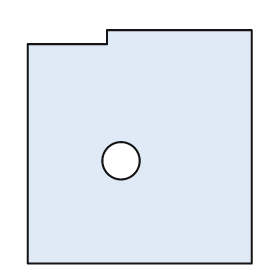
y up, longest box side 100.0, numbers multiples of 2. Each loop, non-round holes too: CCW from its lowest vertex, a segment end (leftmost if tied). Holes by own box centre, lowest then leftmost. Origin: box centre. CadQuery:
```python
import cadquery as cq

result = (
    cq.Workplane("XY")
    .moveTo(-48.0, -50.0)
    .lineTo(48.0, -50.0)
    .lineTo(48.0, 50.0)
    .lineTo(-14.0, 50.0)
    .lineTo(-14.0, 44.0)
    .lineTo(-48.0, 44.0)
    .close()
    .moveTo(-8.0, -6.0)
    .circle(8.0)
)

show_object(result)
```